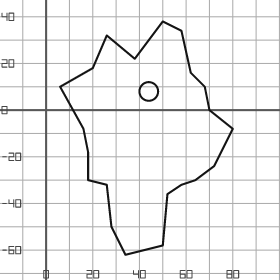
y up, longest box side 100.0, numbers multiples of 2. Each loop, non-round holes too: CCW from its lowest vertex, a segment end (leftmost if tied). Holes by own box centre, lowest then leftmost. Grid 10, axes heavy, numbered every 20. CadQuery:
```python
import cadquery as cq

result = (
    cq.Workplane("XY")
    .moveTo(34.0, -62.0)
    .lineTo(50.0, -58.0)
    .lineTo(52.0, -36.0)
    .lineTo(58.0, -32.0)
    .lineTo(64.0, -30.0)
    .lineTo(72.0, -24.0)
    .lineTo(80.0, -8.0)
    .lineTo(70.0, 0.0)
    .lineTo(68.0, 10.0)
    .lineTo(62.0, 16.0)
    .lineTo(58.0, 34.0)
    .lineTo(50.0, 38.0)
    .lineTo(38.0, 22.0)
    .lineTo(26.0, 32.0)
    .lineTo(20.0, 18.0)
    .lineTo(6.0, 10.0)
    .lineTo(16.0, -8.0)
    .lineTo(18.0, -18.0)
    .lineTo(18.0, -30.0)
    .lineTo(26.0, -32.0)
    .lineTo(28.0, -50.0)
    .close()
    .moveTo(44.0, 8.0)
    .circle(4.0)
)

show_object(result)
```